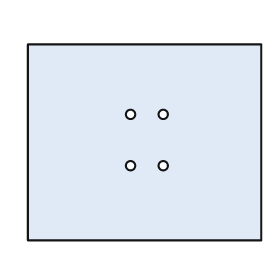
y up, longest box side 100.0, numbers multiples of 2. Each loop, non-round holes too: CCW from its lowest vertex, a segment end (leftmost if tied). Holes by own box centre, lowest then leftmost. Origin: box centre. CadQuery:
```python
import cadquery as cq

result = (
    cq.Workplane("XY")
    .moveTo(-50.0, -42.0)
    .lineTo(50.0, -42.0)
    .lineTo(50.0, 42.0)
    .lineTo(-50.0, 42.0)
    .close()
    .moveTo(-6.0, -10.0)
    .circle(2.0)
    .moveTo(8.0, -10.0)
    .circle(2.0)
    .moveTo(-6.0, 12.0)
    .circle(2.0)
    .moveTo(8.0, 12.0)
    .circle(2.0)
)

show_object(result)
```